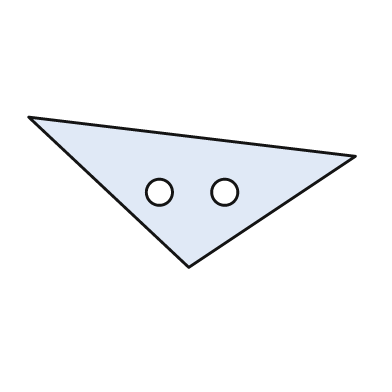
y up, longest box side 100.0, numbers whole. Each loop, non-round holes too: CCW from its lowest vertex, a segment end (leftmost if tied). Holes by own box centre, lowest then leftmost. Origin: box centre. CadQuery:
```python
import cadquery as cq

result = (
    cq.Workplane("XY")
    .moveTo(-1.0, -23.0)
    .lineTo(50.0, 11.0)
    .lineTo(-50.0, 23.0)
    .close()
    .moveTo(-10.0, 0.0)
    .circle(4.0)
    .moveTo(10.0, 0.0)
    .circle(4.0)
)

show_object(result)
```